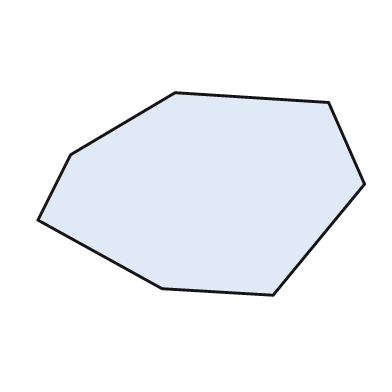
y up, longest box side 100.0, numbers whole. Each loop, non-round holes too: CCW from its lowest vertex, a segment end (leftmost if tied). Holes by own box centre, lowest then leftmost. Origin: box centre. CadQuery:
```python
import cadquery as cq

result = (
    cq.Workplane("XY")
    .moveTo(22.0, -31.0)
    .lineTo(50.0, 3.0)
    .lineTo(39.0, 28.0)
    .lineTo(-8.0, 31.0)
    .lineTo(-40.0, 12.0)
    .lineTo(-50.0, -8.0)
    .lineTo(-12.0, -29.0)
    .close()
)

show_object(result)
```